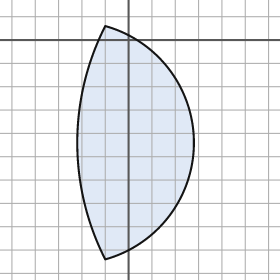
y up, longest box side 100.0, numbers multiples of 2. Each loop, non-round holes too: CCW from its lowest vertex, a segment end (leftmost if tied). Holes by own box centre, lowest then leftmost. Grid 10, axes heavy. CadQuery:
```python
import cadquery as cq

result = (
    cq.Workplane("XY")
    .moveTo(-10.0, -94.0)
    .threePointArc((28.0, -44.0), (-10.0, 6.0))
    .threePointArc((-22.0, -44.0), (-10.0, -94.0))
    .close()
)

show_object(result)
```